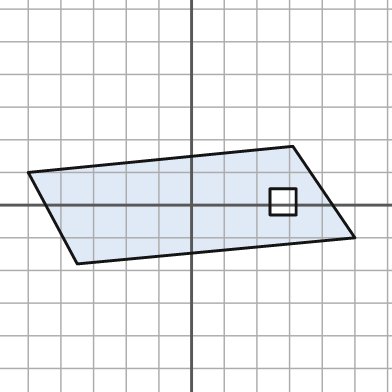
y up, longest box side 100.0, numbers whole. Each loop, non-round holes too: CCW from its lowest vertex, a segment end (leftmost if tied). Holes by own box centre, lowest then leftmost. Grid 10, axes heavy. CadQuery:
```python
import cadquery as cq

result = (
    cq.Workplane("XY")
    .moveTo(-35.0, -18.0)
    .lineTo(50.0, -10.0)
    .lineTo(31.0, 18.0)
    .lineTo(-50.0, 10.0)
    .close()
    .moveTo(24.0, -3.0)
    .lineTo(32.0, -3.0)
    .lineTo(32.0, 5.0)
    .lineTo(24.0, 5.0)
    .close()
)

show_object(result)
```